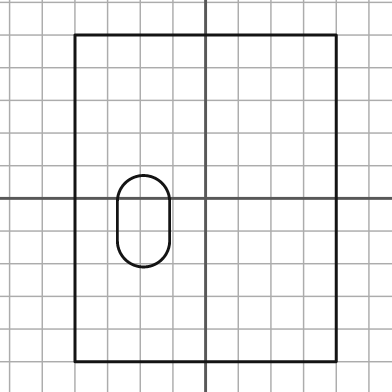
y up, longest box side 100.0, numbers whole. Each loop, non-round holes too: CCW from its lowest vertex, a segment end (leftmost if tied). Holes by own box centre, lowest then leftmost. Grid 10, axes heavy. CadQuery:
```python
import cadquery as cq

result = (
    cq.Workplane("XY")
    .moveTo(-40.0, -50.0)
    .lineTo(40.0, -50.0)
    .lineTo(40.0, 50.0)
    .lineTo(-40.0, 50.0)
    .close()
    .moveTo(-27.0, -13.0)
    .threePointArc((-19.0, -21.0), (-11.0, -13.0))
    .lineTo(-11.0, -1.0)
    .threePointArc((-19.0, 7.0), (-27.0, -1.0))
    .close()
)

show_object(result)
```